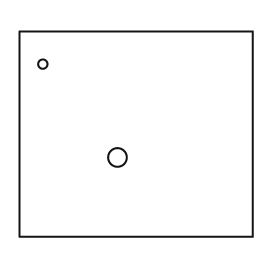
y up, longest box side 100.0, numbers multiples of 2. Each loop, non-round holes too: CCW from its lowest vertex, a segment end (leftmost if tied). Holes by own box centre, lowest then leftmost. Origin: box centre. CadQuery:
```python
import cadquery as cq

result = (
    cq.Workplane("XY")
    .moveTo(-50.0, -44.0)
    .lineTo(50.0, -44.0)
    .lineTo(50.0, 44.0)
    .lineTo(-50.0, 44.0)
    .close()
    .moveTo(-8.0, -10.0)
    .circle(4.0)
    .moveTo(-40.0, 30.0)
    .circle(2.0)
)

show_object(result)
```